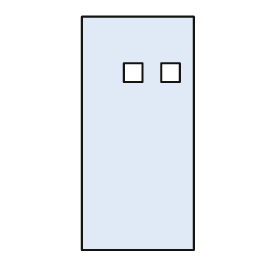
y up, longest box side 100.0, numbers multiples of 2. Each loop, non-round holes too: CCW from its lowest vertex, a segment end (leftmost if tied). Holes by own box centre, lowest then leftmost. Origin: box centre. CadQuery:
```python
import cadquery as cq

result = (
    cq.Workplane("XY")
    .moveTo(-24.0, -50.0)
    .lineTo(24.0, -50.0)
    .lineTo(24.0, 50.0)
    .lineTo(-24.0, 50.0)
    .close()
    .moveTo(-6.0, 22.0)
    .lineTo(2.0, 22.0)
    .lineTo(2.0, 30.0)
    .lineTo(-6.0, 30.0)
    .close()
    .moveTo(10.0, 22.0)
    .lineTo(18.0, 22.0)
    .lineTo(18.0, 30.0)
    .lineTo(10.0, 30.0)
    .close()
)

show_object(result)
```